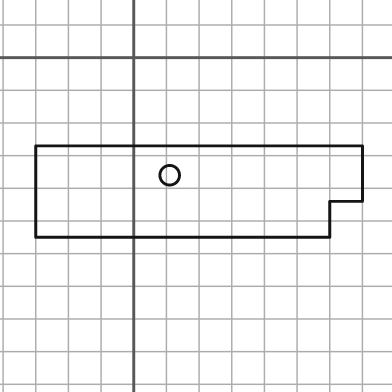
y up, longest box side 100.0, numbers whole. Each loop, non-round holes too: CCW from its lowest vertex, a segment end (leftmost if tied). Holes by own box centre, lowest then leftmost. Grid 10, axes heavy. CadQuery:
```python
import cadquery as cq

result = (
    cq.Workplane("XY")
    .moveTo(-30.0, -55.0)
    .lineTo(60.0, -55.0)
    .lineTo(60.0, -44.0)
    .lineTo(70.0, -44.0)
    .lineTo(70.0, -27.0)
    .lineTo(-30.0, -27.0)
    .close()
    .moveTo(11.0, -36.0)
    .circle(3.0)
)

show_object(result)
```